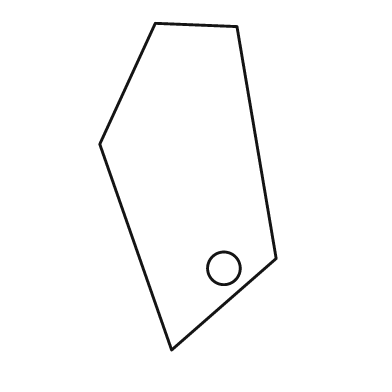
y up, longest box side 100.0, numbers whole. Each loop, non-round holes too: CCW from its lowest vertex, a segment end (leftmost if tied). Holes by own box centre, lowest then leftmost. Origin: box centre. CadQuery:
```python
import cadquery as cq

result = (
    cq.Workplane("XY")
    .moveTo(-5.0, -50.0)
    .lineTo(27.0, -22.0)
    .lineTo(15.0, 49.0)
    .lineTo(-10.0, 50.0)
    .lineTo(-27.0, 13.0)
    .close()
    .moveTo(11.0, -25.0)
    .circle(5.0)
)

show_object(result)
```